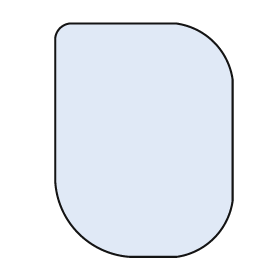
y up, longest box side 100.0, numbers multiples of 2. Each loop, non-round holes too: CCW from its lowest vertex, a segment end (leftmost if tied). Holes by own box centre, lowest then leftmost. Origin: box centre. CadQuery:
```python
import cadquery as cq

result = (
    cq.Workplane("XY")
    .moveTo(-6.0, -50.0)
    .lineTo(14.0, -50.0)
    .threePointArc((30.0, -42.0), (38.0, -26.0))
    .lineTo(38.0, 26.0)
    .threePointArc((30.0, 42.0), (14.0, 50.0))
    .lineTo(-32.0, 50.0)
    .threePointArc((-36.0, 48.0), (-38.0, 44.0))
    .lineTo(-38.0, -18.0)
    .threePointArc((-28.0, -40.0), (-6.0, -50.0))
    .close()
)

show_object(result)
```